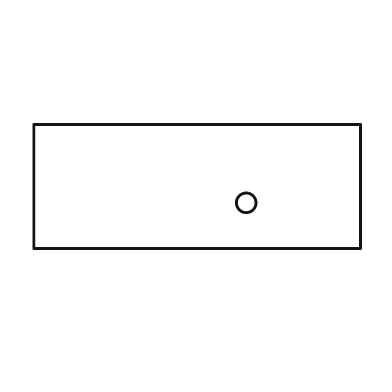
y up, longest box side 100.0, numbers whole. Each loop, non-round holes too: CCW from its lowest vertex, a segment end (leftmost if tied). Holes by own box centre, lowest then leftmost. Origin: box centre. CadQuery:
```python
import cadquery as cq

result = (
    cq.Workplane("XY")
    .moveTo(-50.0, -19.0)
    .lineTo(50.0, -19.0)
    .lineTo(50.0, 19.0)
    .lineTo(-50.0, 19.0)
    .close()
    .moveTo(15.0, -5.0)
    .circle(3.0)
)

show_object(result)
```